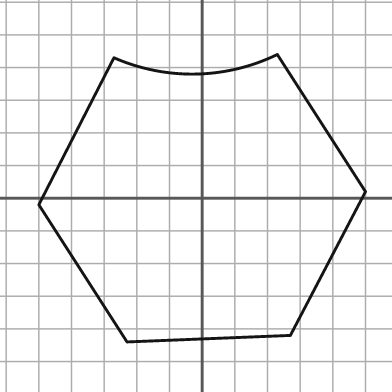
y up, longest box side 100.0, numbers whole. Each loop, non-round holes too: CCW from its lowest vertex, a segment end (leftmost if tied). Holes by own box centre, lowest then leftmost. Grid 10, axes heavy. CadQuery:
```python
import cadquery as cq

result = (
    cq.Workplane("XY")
    .moveTo(-23.0, -44.0)
    .lineTo(27.0, -42.0)
    .lineTo(50.0, 2.0)
    .lineTo(23.0, 44.0)
    .threePointArc((-2.0, 38.0), (-27.0, 43.0))
    .lineTo(-50.0, -2.0)
    .close()
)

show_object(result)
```